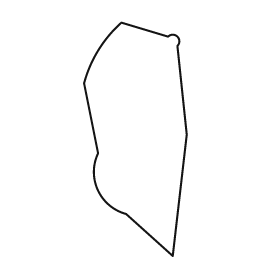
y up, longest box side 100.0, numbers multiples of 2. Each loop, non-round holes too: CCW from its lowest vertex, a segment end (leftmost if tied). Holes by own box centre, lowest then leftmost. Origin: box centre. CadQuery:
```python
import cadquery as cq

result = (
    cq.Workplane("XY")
    .moveTo(16.0, -50.0)
    .lineTo(22.0, 2.0)
    .lineTo(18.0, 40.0)
    .threePointArc((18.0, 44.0), (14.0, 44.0))
    .lineTo(-6.0, 50.0)
    .threePointArc((-16.0, 38.0), (-22.0, 24.0))
    .lineTo(-16.0, -6.0)
    .threePointArc((-16.0, -22.0), (-4.0, -32.0))
    .close()
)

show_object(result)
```